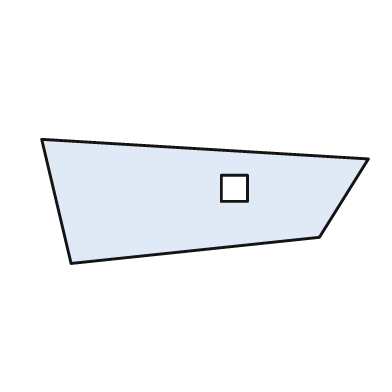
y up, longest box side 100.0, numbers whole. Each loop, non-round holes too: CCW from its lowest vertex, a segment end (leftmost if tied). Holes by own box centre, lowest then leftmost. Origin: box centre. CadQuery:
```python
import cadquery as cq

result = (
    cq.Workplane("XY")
    .moveTo(-41.0, -19.0)
    .lineTo(35.0, -11.0)
    .lineTo(50.0, 13.0)
    .lineTo(-50.0, 19.0)
    .close()
    .moveTo(5.0, 0.0)
    .lineTo(13.0, 0.0)
    .lineTo(13.0, 8.0)
    .lineTo(5.0, 8.0)
    .close()
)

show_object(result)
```